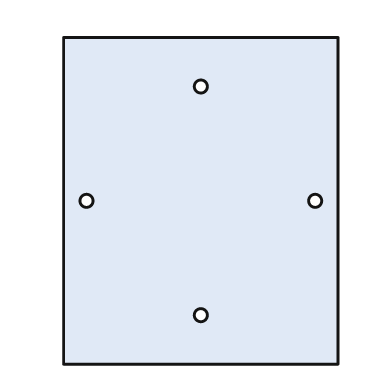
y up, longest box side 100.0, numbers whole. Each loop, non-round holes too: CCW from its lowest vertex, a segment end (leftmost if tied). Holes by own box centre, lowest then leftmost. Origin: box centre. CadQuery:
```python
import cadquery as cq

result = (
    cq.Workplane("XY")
    .moveTo(-42.0, -50.0)
    .lineTo(42.0, -50.0)
    .lineTo(42.0, 50.0)
    .lineTo(-42.0, 50.0)
    .close()
    .moveTo(0.0, -35.0)
    .circle(2.0)
    .moveTo(-35.0, 0.0)
    .circle(2.0)
    .moveTo(35.0, 0.0)
    .circle(2.0)
    .moveTo(0.0, 35.0)
    .circle(2.0)
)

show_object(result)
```